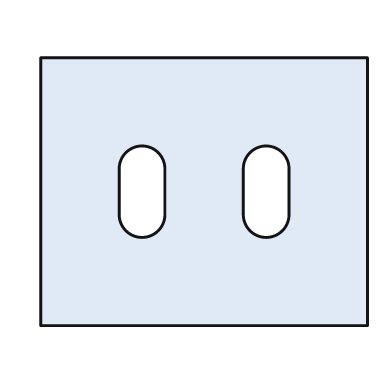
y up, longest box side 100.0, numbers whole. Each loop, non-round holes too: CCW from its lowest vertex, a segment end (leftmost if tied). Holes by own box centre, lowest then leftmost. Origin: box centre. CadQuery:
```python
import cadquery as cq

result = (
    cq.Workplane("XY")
    .moveTo(-50.0, -41.0)
    .lineTo(50.0, -41.0)
    .lineTo(50.0, 41.0)
    .lineTo(-50.0, 41.0)
    .close()
    .moveTo(-26.0, -7.0)
    .threePointArc((-19.0, -14.0), (-12.0, -7.0))
    .lineTo(-12.0, 7.0)
    .threePointArc((-19.0, 14.0), (-26.0, 7.0))
    .close()
    .moveTo(12.0, -7.0)
    .threePointArc((19.0, -14.0), (26.0, -7.0))
    .lineTo(26.0, 7.0)
    .threePointArc((19.0, 14.0), (12.0, 7.0))
    .close()
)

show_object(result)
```